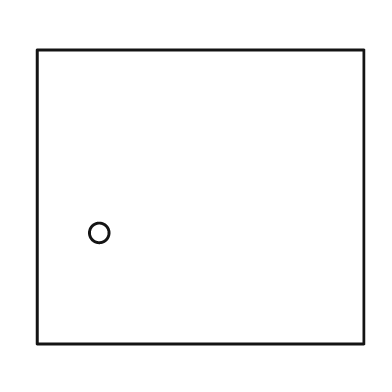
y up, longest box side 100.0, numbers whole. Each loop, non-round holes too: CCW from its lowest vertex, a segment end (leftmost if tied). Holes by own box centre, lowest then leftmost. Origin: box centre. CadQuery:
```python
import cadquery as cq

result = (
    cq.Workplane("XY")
    .moveTo(-50.0, -45.0)
    .lineTo(50.0, -45.0)
    .lineTo(50.0, 45.0)
    .lineTo(-50.0, 45.0)
    .close()
    .moveTo(-31.0, -11.0)
    .circle(3.0)
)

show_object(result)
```